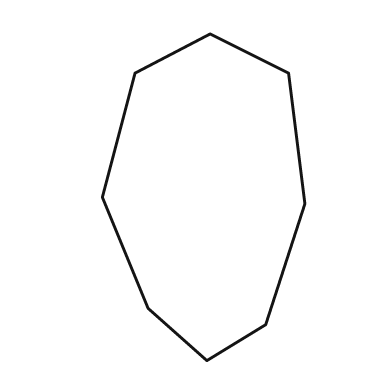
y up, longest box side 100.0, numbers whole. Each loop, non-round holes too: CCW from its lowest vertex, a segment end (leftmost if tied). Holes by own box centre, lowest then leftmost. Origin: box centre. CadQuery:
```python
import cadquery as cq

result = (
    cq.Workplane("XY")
    .moveTo(1.0, -50.0)
    .lineTo(19.0, -39.0)
    .lineTo(31.0, -2.0)
    .lineTo(26.0, 38.0)
    .lineTo(2.0, 50.0)
    .lineTo(-21.0, 38.0)
    .lineTo(-31.0, 0.0)
    .lineTo(-17.0, -34.0)
    .close()
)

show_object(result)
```